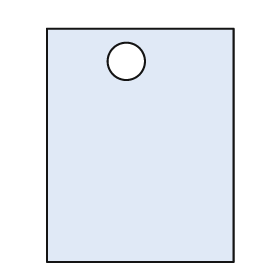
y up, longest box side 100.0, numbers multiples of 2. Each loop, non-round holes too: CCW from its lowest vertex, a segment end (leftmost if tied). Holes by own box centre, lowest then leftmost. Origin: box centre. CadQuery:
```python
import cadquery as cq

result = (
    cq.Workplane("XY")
    .moveTo(-40.0, -50.0)
    .lineTo(40.0, -50.0)
    .lineTo(40.0, 50.0)
    .lineTo(-40.0, 50.0)
    .close()
    .moveTo(-6.0, 36.0)
    .circle(8.0)
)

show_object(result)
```